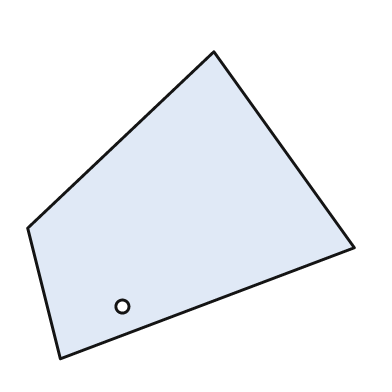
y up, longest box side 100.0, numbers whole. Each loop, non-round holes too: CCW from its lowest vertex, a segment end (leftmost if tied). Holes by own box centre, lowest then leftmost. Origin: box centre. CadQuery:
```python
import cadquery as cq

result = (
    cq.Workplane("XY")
    .moveTo(-40.0, -47.0)
    .lineTo(50.0, -13.0)
    .lineTo(7.0, 47.0)
    .lineTo(-50.0, -7.0)
    .close()
    .moveTo(-21.0, -31.0)
    .circle(2.0)
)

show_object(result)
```